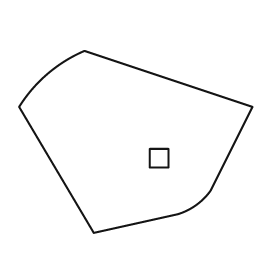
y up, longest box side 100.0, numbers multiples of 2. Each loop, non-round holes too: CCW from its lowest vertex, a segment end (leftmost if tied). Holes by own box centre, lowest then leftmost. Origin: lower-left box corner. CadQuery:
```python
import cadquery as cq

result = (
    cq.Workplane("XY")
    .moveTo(32.0, 0.0)
    .lineTo(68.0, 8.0)
    .threePointArc((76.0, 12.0), (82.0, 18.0))
    .lineTo(100.0, 54.0)
    .lineTo(28.0, 78.0)
    .threePointArc((12.0, 68.0), (0.0, 54.0))
    .close()
    .moveTo(56.0, 28.0)
    .lineTo(64.0, 28.0)
    .lineTo(64.0, 36.0)
    .lineTo(56.0, 36.0)
    .close()
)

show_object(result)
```